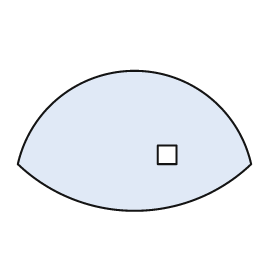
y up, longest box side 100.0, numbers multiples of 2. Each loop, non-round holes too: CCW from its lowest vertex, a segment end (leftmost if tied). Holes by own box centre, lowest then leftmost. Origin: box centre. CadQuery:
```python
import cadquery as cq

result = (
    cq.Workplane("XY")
    .moveTo(-50.0, -10.0)
    .threePointArc((0.0, -30.0), (50.0, -10.0))
    .threePointArc((0.0, 30.0), (-50.0, -10.0))
    .close()
    .moveTo(10.0, -10.0)
    .lineTo(18.0, -10.0)
    .lineTo(18.0, -2.0)
    .lineTo(10.0, -2.0)
    .close()
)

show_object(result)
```